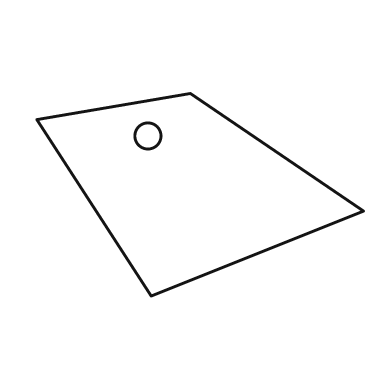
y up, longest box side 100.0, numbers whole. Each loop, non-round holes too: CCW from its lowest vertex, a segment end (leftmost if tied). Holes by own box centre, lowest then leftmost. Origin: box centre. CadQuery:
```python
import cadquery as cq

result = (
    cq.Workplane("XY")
    .moveTo(-15.0, -31.0)
    .lineTo(50.0, -5.0)
    .lineTo(-3.0, 31.0)
    .lineTo(-50.0, 23.0)
    .close()
    .moveTo(-16.0, 18.0)
    .circle(4.0)
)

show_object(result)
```